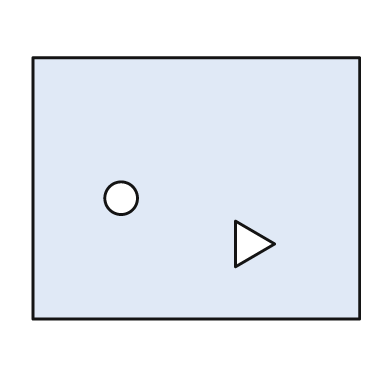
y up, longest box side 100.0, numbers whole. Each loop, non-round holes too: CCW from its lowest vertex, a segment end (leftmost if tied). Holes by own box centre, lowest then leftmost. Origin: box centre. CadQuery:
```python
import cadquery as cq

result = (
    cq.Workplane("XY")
    .moveTo(-50.0, -40.0)
    .lineTo(50.0, -40.0)
    .lineTo(50.0, 40.0)
    .lineTo(-50.0, 40.0)
    .close()
    .moveTo(12.0, -24.0)
    .lineTo(24.0, -17.0)
    .lineTo(12.0, -10.0)
    .close()
    .moveTo(-23.0, -3.0)
    .circle(5.0)
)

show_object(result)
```